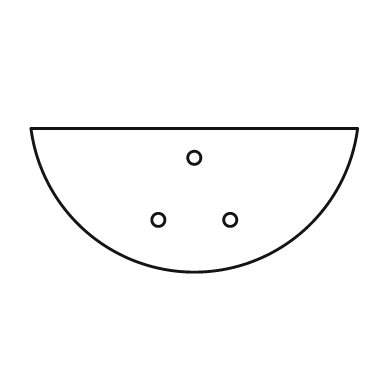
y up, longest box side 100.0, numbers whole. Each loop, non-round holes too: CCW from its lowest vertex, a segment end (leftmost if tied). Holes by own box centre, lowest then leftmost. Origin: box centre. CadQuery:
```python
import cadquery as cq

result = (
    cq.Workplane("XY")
    .moveTo(-50.0, 22.0)
    .threePointArc((0.0, -22.0), (50.0, 22.0))
    .close()
    .moveTo(-11.0, -6.0)
    .circle(2.0)
    .moveTo(11.0, -6.0)
    .circle(2.0)
    .moveTo(0.0, 13.0)
    .circle(2.0)
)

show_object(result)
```